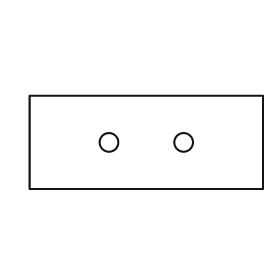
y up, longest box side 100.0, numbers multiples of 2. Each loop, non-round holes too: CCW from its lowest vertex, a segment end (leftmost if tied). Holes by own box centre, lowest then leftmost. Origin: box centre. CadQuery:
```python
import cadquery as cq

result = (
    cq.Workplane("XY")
    .moveTo(-50.0, -20.0)
    .lineTo(50.0, -20.0)
    .lineTo(50.0, 20.0)
    .lineTo(-50.0, 20.0)
    .close()
    .moveTo(-16.0, 0.0)
    .circle(4.0)
    .moveTo(16.0, 0.0)
    .circle(4.0)
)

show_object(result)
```